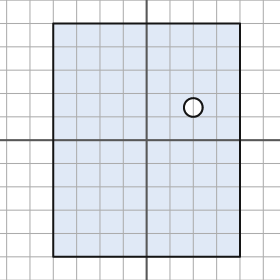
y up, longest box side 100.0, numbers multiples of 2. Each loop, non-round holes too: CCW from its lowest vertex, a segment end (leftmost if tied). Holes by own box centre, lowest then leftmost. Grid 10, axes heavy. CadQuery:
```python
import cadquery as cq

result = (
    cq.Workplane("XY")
    .moveTo(-40.0, -50.0)
    .lineTo(40.0, -50.0)
    .lineTo(40.0, 50.0)
    .lineTo(-40.0, 50.0)
    .close()
    .moveTo(20.0, 14.0)
    .circle(4.0)
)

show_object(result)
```